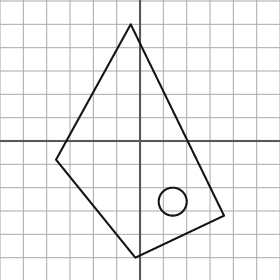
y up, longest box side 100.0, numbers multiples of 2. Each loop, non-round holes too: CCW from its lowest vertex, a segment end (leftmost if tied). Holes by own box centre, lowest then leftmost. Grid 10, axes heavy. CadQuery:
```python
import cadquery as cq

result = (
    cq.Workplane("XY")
    .moveTo(-2.0, -50.0)
    .lineTo(36.0, -32.0)
    .lineTo(-4.0, 50.0)
    .lineTo(-36.0, -8.0)
    .close()
    .moveTo(14.0, -26.0)
    .circle(6.0)
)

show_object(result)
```